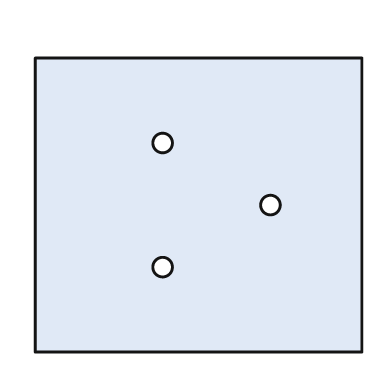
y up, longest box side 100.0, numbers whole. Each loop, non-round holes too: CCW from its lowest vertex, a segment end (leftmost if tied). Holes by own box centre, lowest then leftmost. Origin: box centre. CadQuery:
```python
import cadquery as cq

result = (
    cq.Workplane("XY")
    .moveTo(-50.0, -45.0)
    .lineTo(50.0, -45.0)
    .lineTo(50.0, 45.0)
    .lineTo(-50.0, 45.0)
    .close()
    .moveTo(-11.0, -19.0)
    .circle(3.0)
    .moveTo(22.0, 0.0)
    .circle(3.0)
    .moveTo(-11.0, 19.0)
    .circle(3.0)
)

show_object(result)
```